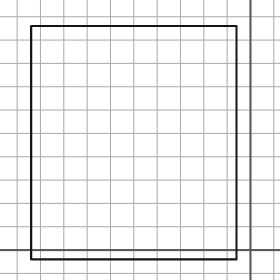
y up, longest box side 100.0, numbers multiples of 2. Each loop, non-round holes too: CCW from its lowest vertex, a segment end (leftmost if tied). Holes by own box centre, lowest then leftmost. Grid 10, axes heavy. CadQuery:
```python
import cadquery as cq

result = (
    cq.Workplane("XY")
    .moveTo(-94.0, -4.0)
    .lineTo(-6.0, -4.0)
    .lineTo(-6.0, 96.0)
    .lineTo(-94.0, 96.0)
    .close()
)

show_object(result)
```